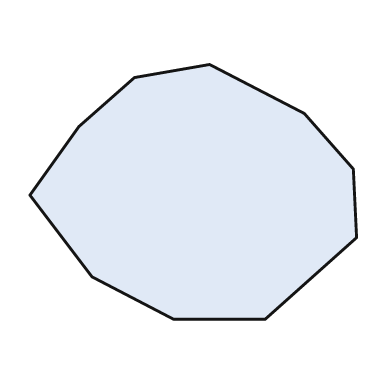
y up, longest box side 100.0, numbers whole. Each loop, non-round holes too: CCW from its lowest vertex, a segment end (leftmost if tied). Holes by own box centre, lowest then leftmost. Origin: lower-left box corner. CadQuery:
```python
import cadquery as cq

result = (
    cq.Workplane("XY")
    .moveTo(44.0, 0.0)
    .lineTo(72.0, 0.0)
    .lineTo(100.0, 25.0)
    .lineTo(99.0, 46.0)
    .lineTo(84.0, 63.0)
    .lineTo(55.0, 78.0)
    .lineTo(32.0, 74.0)
    .lineTo(15.0, 59.0)
    .lineTo(0.0, 38.0)
    .lineTo(19.0, 13.0)
    .close()
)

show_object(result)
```